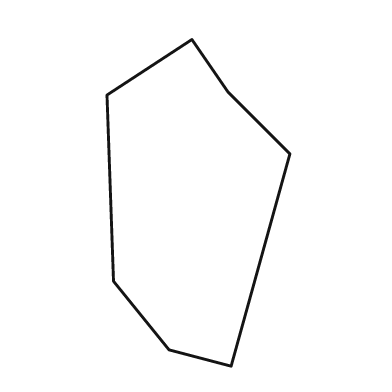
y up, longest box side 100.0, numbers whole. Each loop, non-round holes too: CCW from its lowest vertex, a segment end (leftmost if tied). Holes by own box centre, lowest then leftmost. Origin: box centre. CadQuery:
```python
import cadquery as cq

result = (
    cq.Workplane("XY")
    .moveTo(10.0, -50.0)
    .lineTo(28.0, 15.0)
    .lineTo(9.0, 34.0)
    .lineTo(-2.0, 50.0)
    .lineTo(-28.0, 33.0)
    .lineTo(-26.0, -24.0)
    .lineTo(-9.0, -45.0)
    .close()
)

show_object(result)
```